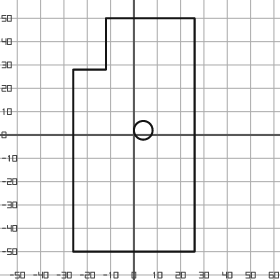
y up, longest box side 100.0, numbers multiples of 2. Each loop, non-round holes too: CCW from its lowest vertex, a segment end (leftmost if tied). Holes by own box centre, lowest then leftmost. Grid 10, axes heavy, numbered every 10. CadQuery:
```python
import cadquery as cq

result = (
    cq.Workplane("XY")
    .moveTo(-26.0, -50.0)
    .lineTo(26.0, -50.0)
    .lineTo(26.0, 50.0)
    .lineTo(-12.0, 50.0)
    .lineTo(-12.0, 28.0)
    .lineTo(-26.0, 28.0)
    .close()
    .moveTo(4.0, 2.0)
    .circle(4.0)
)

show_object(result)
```